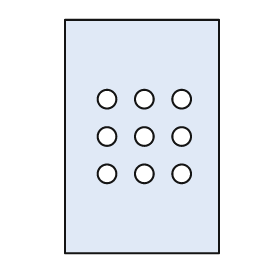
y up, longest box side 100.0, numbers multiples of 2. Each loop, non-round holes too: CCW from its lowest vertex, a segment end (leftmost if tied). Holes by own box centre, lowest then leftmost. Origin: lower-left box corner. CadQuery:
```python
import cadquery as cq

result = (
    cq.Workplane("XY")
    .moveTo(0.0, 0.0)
    .lineTo(66.0, 0.0)
    .lineTo(66.0, 100.0)
    .lineTo(0.0, 100.0)
    .close()
    .moveTo(18.0, 34.0)
    .circle(4.0)
    .moveTo(34.0, 34.0)
    .circle(4.0)
    .moveTo(50.0, 34.0)
    .circle(4.0)
    .moveTo(18.0, 50.0)
    .circle(4.0)
    .moveTo(34.0, 50.0)
    .circle(4.0)
    .moveTo(50.0, 50.0)
    .circle(4.0)
    .moveTo(18.0, 66.0)
    .circle(4.0)
    .moveTo(34.0, 66.0)
    .circle(4.0)
    .moveTo(50.0, 66.0)
    .circle(4.0)
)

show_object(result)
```